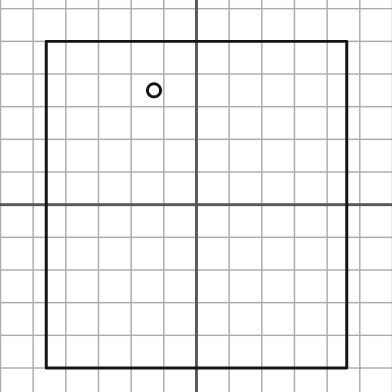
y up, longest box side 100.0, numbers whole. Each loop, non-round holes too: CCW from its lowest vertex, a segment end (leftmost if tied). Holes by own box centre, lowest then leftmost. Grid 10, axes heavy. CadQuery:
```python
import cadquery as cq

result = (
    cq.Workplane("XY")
    .moveTo(-46.0, -50.0)
    .lineTo(46.0, -50.0)
    .lineTo(46.0, 50.0)
    .lineTo(-46.0, 50.0)
    .close()
    .moveTo(-13.0, 35.0)
    .circle(2.0)
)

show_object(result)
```